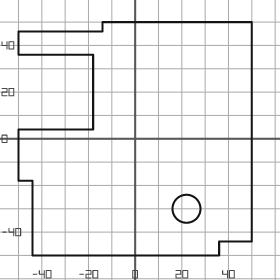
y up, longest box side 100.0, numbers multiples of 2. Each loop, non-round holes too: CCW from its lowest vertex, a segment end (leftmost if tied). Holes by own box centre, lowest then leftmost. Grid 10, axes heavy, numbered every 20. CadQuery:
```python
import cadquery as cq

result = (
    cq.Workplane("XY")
    .moveTo(-44.0, -50.0)
    .lineTo(36.0, -50.0)
    .lineTo(36.0, -44.0)
    .lineTo(50.0, -44.0)
    .lineTo(50.0, 50.0)
    .lineTo(-14.0, 50.0)
    .lineTo(-14.0, 46.0)
    .lineTo(-50.0, 46.0)
    .lineTo(-50.0, 36.0)
    .lineTo(-18.0, 36.0)
    .lineTo(-18.0, 4.0)
    .lineTo(-50.0, 4.0)
    .lineTo(-50.0, -18.0)
    .lineTo(-44.0, -18.0)
    .close()
    .moveTo(22.0, -30.0)
    .circle(6.0)
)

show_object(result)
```